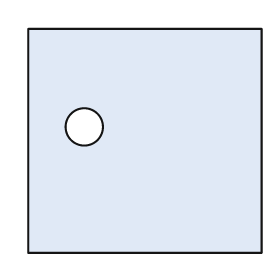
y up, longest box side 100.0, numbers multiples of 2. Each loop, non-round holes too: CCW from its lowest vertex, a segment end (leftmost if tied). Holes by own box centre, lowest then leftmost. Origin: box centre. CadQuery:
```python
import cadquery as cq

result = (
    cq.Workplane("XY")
    .moveTo(-50.0, -48.0)
    .lineTo(50.0, -48.0)
    .lineTo(50.0, 48.0)
    .lineTo(-50.0, 48.0)
    .close()
    .moveTo(-26.0, 6.0)
    .circle(8.0)
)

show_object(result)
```